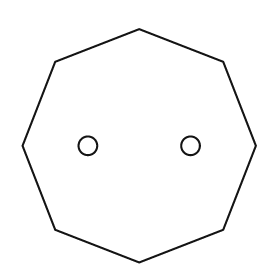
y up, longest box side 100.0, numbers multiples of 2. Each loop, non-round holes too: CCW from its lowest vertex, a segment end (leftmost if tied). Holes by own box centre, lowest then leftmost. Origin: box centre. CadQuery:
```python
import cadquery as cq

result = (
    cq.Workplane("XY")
    .moveTo(0.0, -50.0)
    .lineTo(36.0, -36.0)
    .lineTo(50.0, 0.0)
    .lineTo(36.0, 36.0)
    .lineTo(0.0, 50.0)
    .lineTo(-36.0, 36.0)
    .lineTo(-50.0, 0.0)
    .lineTo(-36.0, -36.0)
    .close()
    .moveTo(-22.0, 0.0)
    .circle(4.0)
    .moveTo(22.0, 0.0)
    .circle(4.0)
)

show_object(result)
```